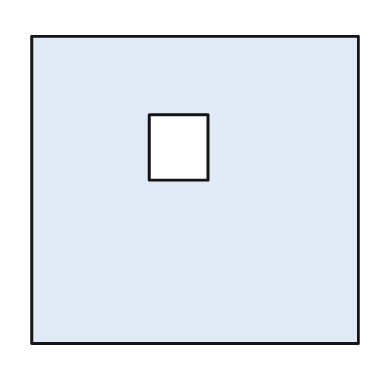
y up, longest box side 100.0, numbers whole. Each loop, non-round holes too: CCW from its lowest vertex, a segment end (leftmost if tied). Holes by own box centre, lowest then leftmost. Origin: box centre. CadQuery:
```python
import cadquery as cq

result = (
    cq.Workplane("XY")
    .moveTo(-50.0, -47.0)
    .lineTo(50.0, -47.0)
    .lineTo(50.0, 47.0)
    .lineTo(-50.0, 47.0)
    .close()
    .moveTo(-14.0, 3.0)
    .lineTo(4.0, 3.0)
    .lineTo(4.0, 23.0)
    .lineTo(-14.0, 23.0)
    .close()
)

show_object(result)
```